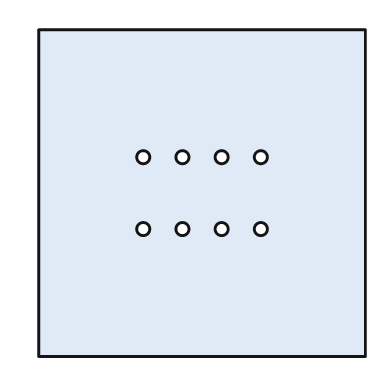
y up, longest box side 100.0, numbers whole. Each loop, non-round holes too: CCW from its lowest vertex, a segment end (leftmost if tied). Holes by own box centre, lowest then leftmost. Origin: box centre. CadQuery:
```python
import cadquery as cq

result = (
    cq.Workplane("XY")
    .moveTo(-50.0, -50.0)
    .lineTo(50.0, -50.0)
    .lineTo(50.0, 50.0)
    .lineTo(-50.0, 50.0)
    .close()
    .moveTo(-18.0, -11.0)
    .circle(2.0)
    .moveTo(-6.0, -11.0)
    .circle(2.0)
    .moveTo(6.0, -11.0)
    .circle(2.0)
    .moveTo(18.0, -11.0)
    .circle(2.0)
    .moveTo(-18.0, 11.0)
    .circle(2.0)
    .moveTo(-6.0, 11.0)
    .circle(2.0)
    .moveTo(6.0, 11.0)
    .circle(2.0)
    .moveTo(18.0, 11.0)
    .circle(2.0)
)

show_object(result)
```